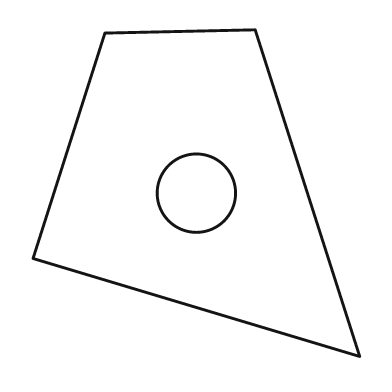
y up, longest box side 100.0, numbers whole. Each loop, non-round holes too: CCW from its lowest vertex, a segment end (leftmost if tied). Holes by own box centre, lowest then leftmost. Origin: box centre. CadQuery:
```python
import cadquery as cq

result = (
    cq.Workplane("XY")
    .moveTo(50.0, -50.0)
    .lineTo(18.0, 50.0)
    .lineTo(-28.0, 49.0)
    .lineTo(-50.0, -20.0)
    .close()
    .moveTo(0.0, 0.0)
    .circle(12.0)
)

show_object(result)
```